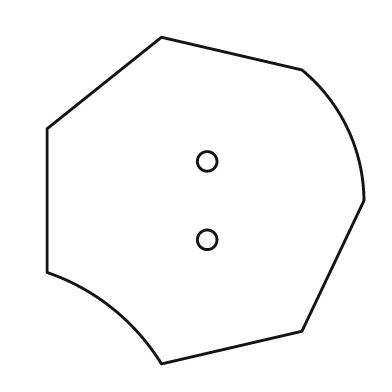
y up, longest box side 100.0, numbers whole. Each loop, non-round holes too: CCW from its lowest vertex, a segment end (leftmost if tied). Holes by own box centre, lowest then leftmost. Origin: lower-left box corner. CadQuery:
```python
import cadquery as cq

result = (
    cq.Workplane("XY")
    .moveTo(35.0, 0.0)
    .lineTo(78.0, 10.0)
    .lineTo(97.0, 50.0)
    .threePointArc((92.0, 72.0), (78.0, 90.0))
    .lineTo(35.0, 100.0)
    .lineTo(0.0, 72.0)
    .lineTo(0.0, 28.0)
    .threePointArc((20.0, 17.0), (35.0, 0.0))
    .close()
    .moveTo(49.0, 38.0)
    .circle(3.0)
    .moveTo(49.0, 62.0)
    .circle(3.0)
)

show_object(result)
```